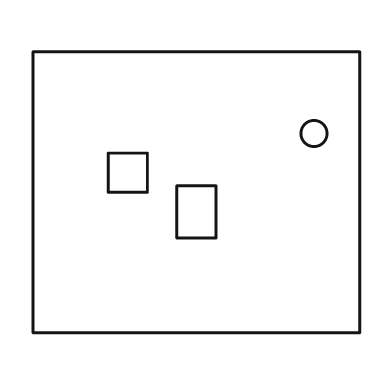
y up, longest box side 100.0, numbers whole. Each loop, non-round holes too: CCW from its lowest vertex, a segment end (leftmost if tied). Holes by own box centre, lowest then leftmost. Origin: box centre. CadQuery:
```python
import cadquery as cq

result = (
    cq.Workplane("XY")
    .moveTo(-50.0, -43.0)
    .lineTo(50.0, -43.0)
    .lineTo(50.0, 43.0)
    .lineTo(-50.0, 43.0)
    .close()
    .moveTo(-6.0, -14.0)
    .lineTo(6.0, -14.0)
    .lineTo(6.0, 2.0)
    .lineTo(-6.0, 2.0)
    .close()
    .moveTo(-27.0, 0.0)
    .lineTo(-15.0, 0.0)
    .lineTo(-15.0, 12.0)
    .lineTo(-27.0, 12.0)
    .close()
    .moveTo(36.0, 18.0)
    .circle(4.0)
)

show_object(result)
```